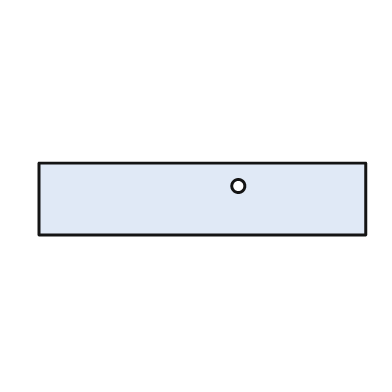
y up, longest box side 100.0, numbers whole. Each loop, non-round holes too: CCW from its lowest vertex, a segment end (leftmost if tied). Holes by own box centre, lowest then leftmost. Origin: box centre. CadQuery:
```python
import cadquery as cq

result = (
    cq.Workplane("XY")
    .moveTo(-50.0, -11.0)
    .lineTo(50.0, -11.0)
    .lineTo(50.0, 11.0)
    .lineTo(-50.0, 11.0)
    .close()
    .moveTo(11.0, 4.0)
    .circle(2.0)
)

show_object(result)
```